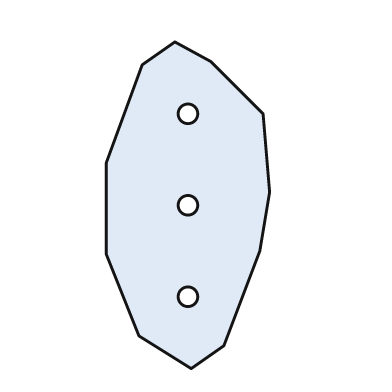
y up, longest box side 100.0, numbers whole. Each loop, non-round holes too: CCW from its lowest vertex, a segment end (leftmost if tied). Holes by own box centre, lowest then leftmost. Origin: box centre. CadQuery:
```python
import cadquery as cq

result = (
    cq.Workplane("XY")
    .moveTo(1.0, -50.0)
    .lineTo(11.0, -43.0)
    .lineTo(22.0, -14.0)
    .lineTo(25.0, 4.0)
    .lineTo(23.0, 28.0)
    .lineTo(7.0, 44.0)
    .lineTo(-4.0, 50.0)
    .lineTo(-14.0, 43.0)
    .lineTo(-25.0, 13.0)
    .lineTo(-25.0, -15.0)
    .lineTo(-15.0, -40.0)
    .close()
    .moveTo(0.0, -28.0)
    .circle(3.0)
    .moveTo(0.0, 0.0)
    .circle(3.0)
    .moveTo(0.0, 28.0)
    .circle(3.0)
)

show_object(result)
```